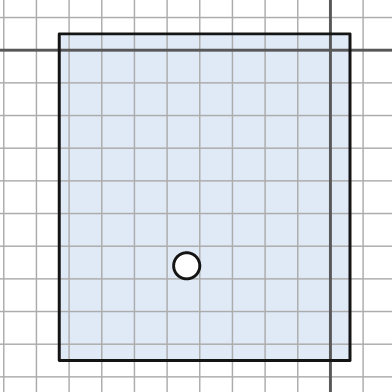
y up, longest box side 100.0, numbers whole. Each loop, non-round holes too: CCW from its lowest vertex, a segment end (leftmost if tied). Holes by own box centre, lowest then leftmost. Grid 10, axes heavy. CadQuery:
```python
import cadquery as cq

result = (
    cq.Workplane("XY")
    .moveTo(-83.0, -95.0)
    .lineTo(6.0, -95.0)
    .lineTo(6.0, 5.0)
    .lineTo(-83.0, 5.0)
    .close()
    .moveTo(-44.0, -66.0)
    .circle(4.0)
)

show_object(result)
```